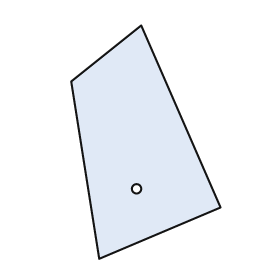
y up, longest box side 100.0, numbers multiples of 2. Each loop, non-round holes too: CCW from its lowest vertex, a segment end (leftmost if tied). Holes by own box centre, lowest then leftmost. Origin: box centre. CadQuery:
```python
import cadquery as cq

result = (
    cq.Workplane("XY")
    .moveTo(-20.0, -50.0)
    .lineTo(32.0, -28.0)
    .lineTo(-2.0, 50.0)
    .lineTo(-32.0, 26.0)
    .close()
    .moveTo(-4.0, -20.0)
    .circle(2.0)
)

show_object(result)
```